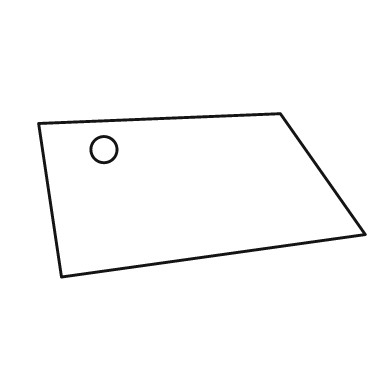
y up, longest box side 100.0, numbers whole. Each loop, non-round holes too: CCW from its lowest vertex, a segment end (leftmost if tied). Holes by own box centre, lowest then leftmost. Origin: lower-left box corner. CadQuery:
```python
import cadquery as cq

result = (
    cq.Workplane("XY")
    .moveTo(7.0, 0.0)
    .lineTo(100.0, 13.0)
    .lineTo(74.0, 50.0)
    .lineTo(0.0, 47.0)
    .close()
    .moveTo(20.0, 39.0)
    .circle(4.0)
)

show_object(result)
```